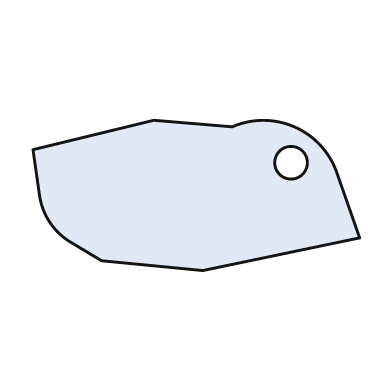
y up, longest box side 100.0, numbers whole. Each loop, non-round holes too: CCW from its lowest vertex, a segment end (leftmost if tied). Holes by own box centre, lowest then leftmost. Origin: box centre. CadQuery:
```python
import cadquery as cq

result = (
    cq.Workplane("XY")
    .moveTo(2.0, -23.0)
    .lineTo(50.0, -13.0)
    .lineTo(43.0, 7.0)
    .threePointArc((30.0, 21.0), (11.0, 21.0))
    .lineTo(-13.0, 23.0)
    .lineTo(-50.0, 14.0)
    .lineTo(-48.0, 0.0)
    .threePointArc((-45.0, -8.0), (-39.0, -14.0))
    .lineTo(-29.0, -20.0)
    .close()
    .moveTo(29.0, 10.0)
    .circle(5.0)
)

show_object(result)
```